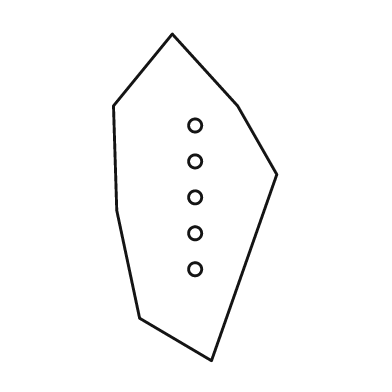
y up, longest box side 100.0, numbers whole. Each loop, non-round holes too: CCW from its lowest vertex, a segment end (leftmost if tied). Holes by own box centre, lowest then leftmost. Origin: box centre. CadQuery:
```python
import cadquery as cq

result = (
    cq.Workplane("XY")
    .moveTo(5.0, -50.0)
    .lineTo(25.0, 7.0)
    .lineTo(13.0, 28.0)
    .lineTo(-7.0, 50.0)
    .lineTo(-25.0, 28.0)
    .lineTo(-24.0, -4.0)
    .lineTo(-17.0, -37.0)
    .close()
    .moveTo(0.0, -22.0)
    .circle(2.0)
    .moveTo(0.0, -11.0)
    .circle(2.0)
    .moveTo(0.0, 0.0)
    .circle(2.0)
    .moveTo(0.0, 11.0)
    .circle(2.0)
    .moveTo(0.0, 22.0)
    .circle(2.0)
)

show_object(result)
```